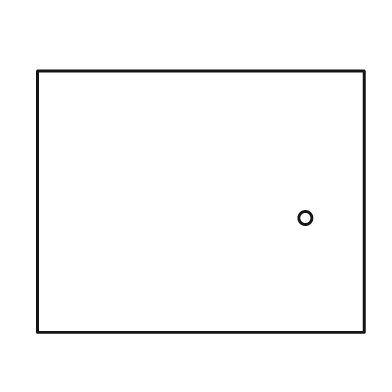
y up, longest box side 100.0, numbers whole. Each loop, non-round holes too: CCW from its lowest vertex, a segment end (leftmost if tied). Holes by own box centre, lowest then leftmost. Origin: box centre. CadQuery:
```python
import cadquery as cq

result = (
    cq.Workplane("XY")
    .moveTo(-50.0, -40.0)
    .lineTo(50.0, -40.0)
    .lineTo(50.0, 40.0)
    .lineTo(-50.0, 40.0)
    .close()
    .moveTo(32.0, -5.0)
    .circle(2.0)
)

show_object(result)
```